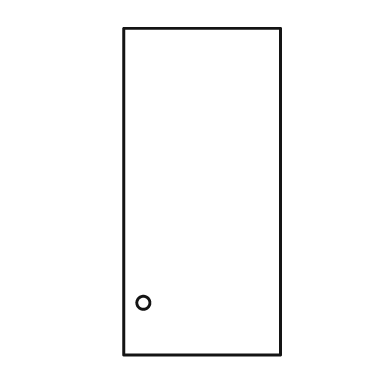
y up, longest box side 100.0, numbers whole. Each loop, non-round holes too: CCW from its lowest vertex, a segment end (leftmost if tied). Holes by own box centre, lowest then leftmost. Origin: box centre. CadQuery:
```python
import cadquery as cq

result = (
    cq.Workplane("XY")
    .moveTo(-24.0, -50.0)
    .lineTo(24.0, -50.0)
    .lineTo(24.0, 50.0)
    .lineTo(-24.0, 50.0)
    .close()
    .moveTo(-18.0, -34.0)
    .circle(2.0)
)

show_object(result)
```